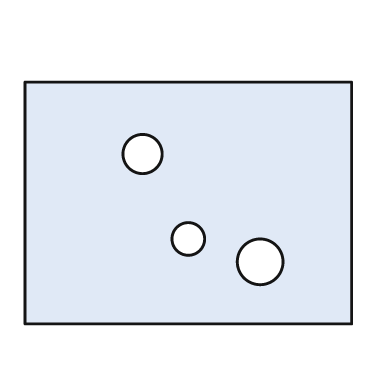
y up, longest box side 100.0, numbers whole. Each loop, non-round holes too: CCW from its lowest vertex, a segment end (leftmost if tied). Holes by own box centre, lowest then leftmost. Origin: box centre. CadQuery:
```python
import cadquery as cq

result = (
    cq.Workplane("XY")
    .moveTo(-50.0, -37.0)
    .lineTo(50.0, -37.0)
    .lineTo(50.0, 37.0)
    .lineTo(-50.0, 37.0)
    .close()
    .moveTo(22.0, -18.0)
    .circle(7.0)
    .moveTo(0.0, -11.0)
    .circle(5.0)
    .moveTo(-14.0, 15.0)
    .circle(6.0)
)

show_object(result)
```